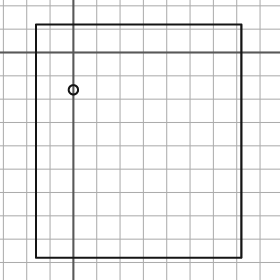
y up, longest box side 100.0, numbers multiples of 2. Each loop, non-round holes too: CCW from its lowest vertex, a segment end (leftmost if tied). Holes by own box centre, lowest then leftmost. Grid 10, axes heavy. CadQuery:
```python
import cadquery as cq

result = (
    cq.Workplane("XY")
    .moveTo(-16.0, -88.0)
    .lineTo(72.0, -88.0)
    .lineTo(72.0, 12.0)
    .lineTo(-16.0, 12.0)
    .close()
    .moveTo(0.0, -16.0)
    .circle(2.0)
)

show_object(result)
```